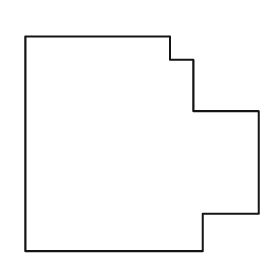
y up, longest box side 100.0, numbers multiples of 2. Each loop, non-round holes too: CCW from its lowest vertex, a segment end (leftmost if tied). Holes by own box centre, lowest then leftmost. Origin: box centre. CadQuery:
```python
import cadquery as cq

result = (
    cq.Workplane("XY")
    .moveTo(-50.0, -46.0)
    .lineTo(26.0, -46.0)
    .lineTo(26.0, -30.0)
    .lineTo(50.0, -30.0)
    .lineTo(50.0, 14.0)
    .lineTo(22.0, 14.0)
    .lineTo(22.0, 36.0)
    .lineTo(12.0, 36.0)
    .lineTo(12.0, 46.0)
    .lineTo(-50.0, 46.0)
    .close()
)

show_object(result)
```